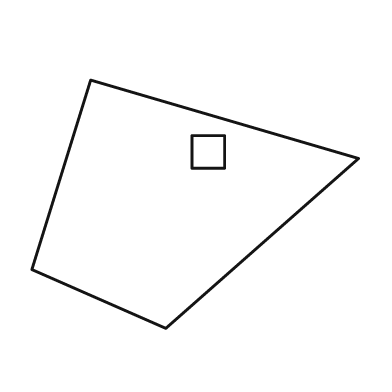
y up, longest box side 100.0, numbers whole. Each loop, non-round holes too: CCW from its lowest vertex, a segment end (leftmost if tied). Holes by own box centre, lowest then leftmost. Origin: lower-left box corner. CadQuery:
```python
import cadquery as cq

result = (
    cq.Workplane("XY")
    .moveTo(41.0, 0.0)
    .lineTo(100.0, 52.0)
    .lineTo(18.0, 76.0)
    .lineTo(0.0, 18.0)
    .close()
    .moveTo(49.0, 49.0)
    .lineTo(59.0, 49.0)
    .lineTo(59.0, 59.0)
    .lineTo(49.0, 59.0)
    .close()
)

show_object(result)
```